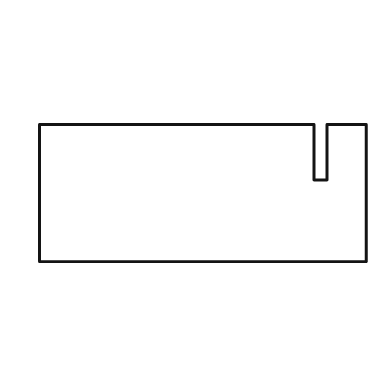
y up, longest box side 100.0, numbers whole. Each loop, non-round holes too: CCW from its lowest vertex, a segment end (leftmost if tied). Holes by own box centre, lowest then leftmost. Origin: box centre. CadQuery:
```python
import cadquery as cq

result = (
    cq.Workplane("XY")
    .moveTo(-50.0, -21.0)
    .lineTo(50.0, -21.0)
    .lineTo(50.0, 21.0)
    .lineTo(38.0, 21.0)
    .lineTo(38.0, 4.0)
    .lineTo(34.0, 4.0)
    .lineTo(34.0, 21.0)
    .lineTo(-50.0, 21.0)
    .close()
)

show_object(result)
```